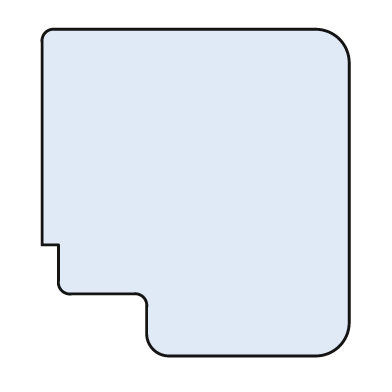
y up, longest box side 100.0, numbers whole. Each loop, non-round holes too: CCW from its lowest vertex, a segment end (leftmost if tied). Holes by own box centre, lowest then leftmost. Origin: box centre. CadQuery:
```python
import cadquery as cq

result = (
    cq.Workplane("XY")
    .moveTo(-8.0, -50.0)
    .lineTo(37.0, -50.0)
    .threePointArc((44.0, -47.0), (47.0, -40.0))
    .lineTo(47.0, 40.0)
    .threePointArc((44.0, 47.0), (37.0, 50.0))
    .lineTo(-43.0, 50.0)
    .threePointArc((-46.0, 49.0), (-47.0, 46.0))
    .lineTo(-47.0, -16.0)
    .lineTo(-42.0, -16.0)
    .lineTo(-42.0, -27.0)
    .threePointArc((-41.0, -30.0), (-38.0, -31.0))
    .lineTo(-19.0, -31.0)
    .threePointArc((-16.0, -32.0), (-15.0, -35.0))
    .lineTo(-15.0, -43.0)
    .threePointArc((-13.0, -48.0), (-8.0, -50.0))
    .close()
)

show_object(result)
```